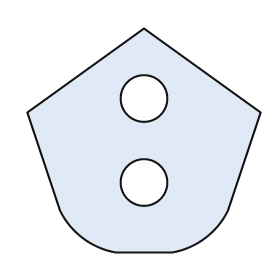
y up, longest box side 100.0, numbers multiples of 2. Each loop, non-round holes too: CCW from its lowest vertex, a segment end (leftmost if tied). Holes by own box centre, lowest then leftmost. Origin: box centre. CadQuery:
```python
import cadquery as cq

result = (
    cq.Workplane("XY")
    .moveTo(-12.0, -48.0)
    .lineTo(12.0, -48.0)
    .threePointArc((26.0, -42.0), (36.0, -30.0))
    .lineTo(50.0, 12.0)
    .lineTo(0.0, 48.0)
    .lineTo(-50.0, 12.0)
    .lineTo(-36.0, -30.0)
    .threePointArc((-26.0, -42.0), (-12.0, -48.0))
    .close()
    .moveTo(0.0, -18.0)
    .circle(10.0)
    .moveTo(0.0, 18.0)
    .circle(10.0)
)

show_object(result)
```